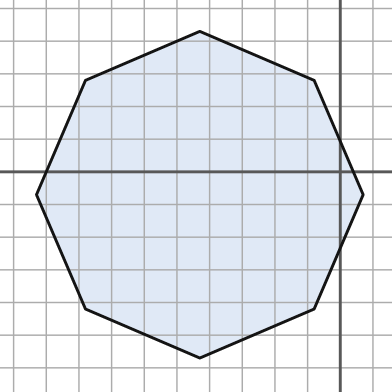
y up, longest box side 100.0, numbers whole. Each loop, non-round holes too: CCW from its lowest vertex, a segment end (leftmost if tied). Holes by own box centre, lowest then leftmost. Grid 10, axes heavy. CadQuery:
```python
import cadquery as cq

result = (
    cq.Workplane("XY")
    .moveTo(-43.0, -57.0)
    .lineTo(-8.0, -42.0)
    .lineTo(7.0, -7.0)
    .lineTo(-8.0, 28.0)
    .lineTo(-43.0, 43.0)
    .lineTo(-78.0, 28.0)
    .lineTo(-93.0, -7.0)
    .lineTo(-78.0, -42.0)
    .close()
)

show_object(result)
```